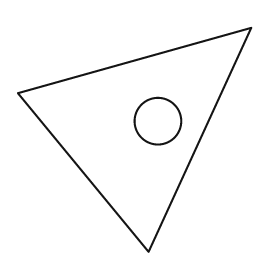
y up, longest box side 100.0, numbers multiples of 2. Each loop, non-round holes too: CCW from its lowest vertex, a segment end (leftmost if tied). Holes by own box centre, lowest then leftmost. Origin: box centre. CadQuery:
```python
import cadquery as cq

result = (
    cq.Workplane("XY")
    .moveTo(6.0, -48.0)
    .lineTo(50.0, 48.0)
    .lineTo(-50.0, 20.0)
    .close()
    .moveTo(10.0, 8.0)
    .circle(10.0)
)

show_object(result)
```